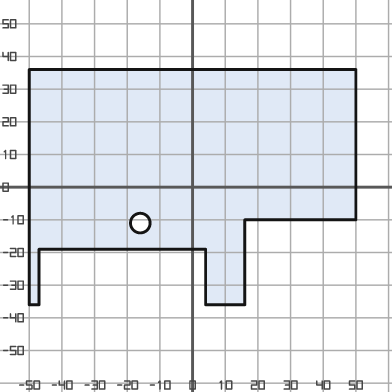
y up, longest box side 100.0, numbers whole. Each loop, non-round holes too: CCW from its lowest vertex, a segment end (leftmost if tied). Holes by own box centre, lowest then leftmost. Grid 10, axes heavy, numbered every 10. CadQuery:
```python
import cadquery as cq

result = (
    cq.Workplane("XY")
    .moveTo(-50.0, -36.0)
    .lineTo(-47.0, -36.0)
    .lineTo(-47.0, -19.0)
    .lineTo(4.0, -19.0)
    .lineTo(4.0, -36.0)
    .lineTo(16.0, -36.0)
    .lineTo(16.0, -10.0)
    .lineTo(50.0, -10.0)
    .lineTo(50.0, 36.0)
    .lineTo(-50.0, 36.0)
    .close()
    .moveTo(-16.0, -11.0)
    .circle(3.0)
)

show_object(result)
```